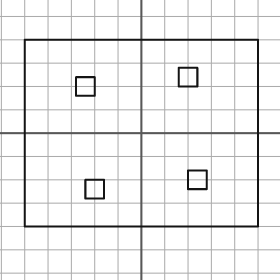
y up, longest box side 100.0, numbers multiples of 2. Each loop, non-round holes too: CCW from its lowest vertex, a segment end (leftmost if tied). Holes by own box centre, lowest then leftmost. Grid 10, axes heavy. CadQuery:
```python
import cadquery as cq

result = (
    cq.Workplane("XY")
    .moveTo(-50.0, -40.0)
    .lineTo(50.0, -40.0)
    .lineTo(50.0, 40.0)
    .lineTo(-50.0, 40.0)
    .close()
    .moveTo(-24.0, -28.0)
    .lineTo(-16.0, -28.0)
    .lineTo(-16.0, -20.0)
    .lineTo(-24.0, -20.0)
    .close()
    .moveTo(20.0, -24.0)
    .lineTo(28.0, -24.0)
    .lineTo(28.0, -16.0)
    .lineTo(20.0, -16.0)
    .close()
    .moveTo(-28.0, 16.0)
    .lineTo(-20.0, 16.0)
    .lineTo(-20.0, 24.0)
    .lineTo(-28.0, 24.0)
    .close()
    .moveTo(16.0, 20.0)
    .lineTo(24.0, 20.0)
    .lineTo(24.0, 28.0)
    .lineTo(16.0, 28.0)
    .close()
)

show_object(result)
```